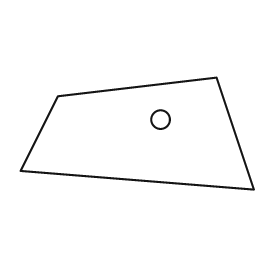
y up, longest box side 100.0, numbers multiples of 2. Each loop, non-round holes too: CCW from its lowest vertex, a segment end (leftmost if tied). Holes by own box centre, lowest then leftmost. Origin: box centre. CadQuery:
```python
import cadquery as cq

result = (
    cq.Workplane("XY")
    .moveTo(50.0, -24.0)
    .lineTo(34.0, 24.0)
    .lineTo(-34.0, 16.0)
    .lineTo(-50.0, -16.0)
    .close()
    .moveTo(10.0, 6.0)
    .circle(4.0)
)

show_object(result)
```